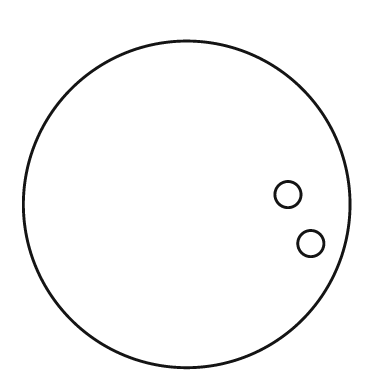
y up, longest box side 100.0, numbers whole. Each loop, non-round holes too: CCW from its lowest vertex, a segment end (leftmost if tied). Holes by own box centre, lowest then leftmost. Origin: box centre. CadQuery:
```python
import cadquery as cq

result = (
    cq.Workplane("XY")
    .moveTo(0.0, 0.0)
    .circle(50.0)
    .moveTo(38.0, -12.0)
    .circle(4.0)
    .moveTo(31.0, 3.0)
    .circle(4.0)
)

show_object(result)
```